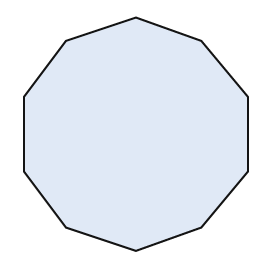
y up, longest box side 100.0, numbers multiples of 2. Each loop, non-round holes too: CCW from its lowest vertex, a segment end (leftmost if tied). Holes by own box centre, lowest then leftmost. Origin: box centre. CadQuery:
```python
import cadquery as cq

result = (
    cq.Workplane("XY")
    .moveTo(0.0, -50.0)
    .lineTo(28.0, -40.0)
    .lineTo(48.0, -16.0)
    .lineTo(48.0, 16.0)
    .lineTo(28.0, 40.0)
    .lineTo(0.0, 50.0)
    .lineTo(-30.0, 40.0)
    .lineTo(-48.0, 16.0)
    .lineTo(-48.0, -16.0)
    .lineTo(-30.0, -40.0)
    .close()
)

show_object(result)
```